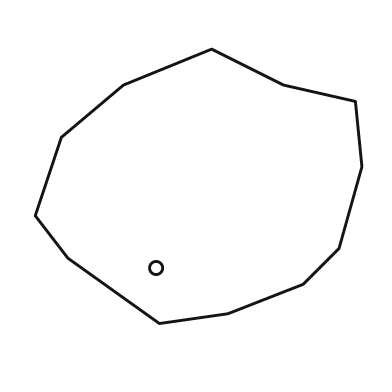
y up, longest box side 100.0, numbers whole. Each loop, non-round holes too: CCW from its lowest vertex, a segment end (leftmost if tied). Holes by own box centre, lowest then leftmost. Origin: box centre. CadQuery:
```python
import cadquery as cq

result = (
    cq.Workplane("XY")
    .moveTo(-12.0, -42.0)
    .lineTo(9.0, -39.0)
    .lineTo(32.0, -30.0)
    .lineTo(43.0, -19.0)
    .lineTo(50.0, 6.0)
    .lineTo(48.0, 26.0)
    .lineTo(26.0, 31.0)
    .lineTo(4.0, 42.0)
    .lineTo(-23.0, 31.0)
    .lineTo(-42.0, 15.0)
    .lineTo(-50.0, -9.0)
    .lineTo(-40.0, -22.0)
    .close()
    .moveTo(-13.0, -25.0)
    .circle(2.0)
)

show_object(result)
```